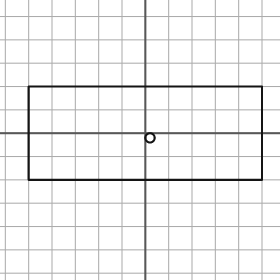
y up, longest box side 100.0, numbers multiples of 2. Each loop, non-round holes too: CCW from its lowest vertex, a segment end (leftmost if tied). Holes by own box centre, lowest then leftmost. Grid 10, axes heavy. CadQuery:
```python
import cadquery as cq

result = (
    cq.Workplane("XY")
    .moveTo(-50.0, -20.0)
    .lineTo(50.0, -20.0)
    .lineTo(50.0, 20.0)
    .lineTo(-50.0, 20.0)
    .close()
    .moveTo(2.0, -2.0)
    .circle(2.0)
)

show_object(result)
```